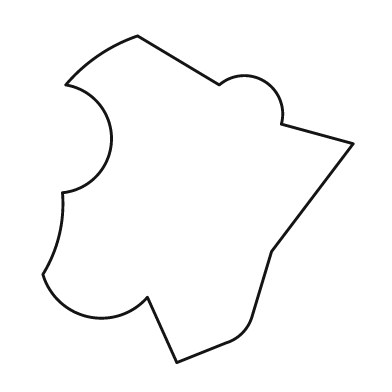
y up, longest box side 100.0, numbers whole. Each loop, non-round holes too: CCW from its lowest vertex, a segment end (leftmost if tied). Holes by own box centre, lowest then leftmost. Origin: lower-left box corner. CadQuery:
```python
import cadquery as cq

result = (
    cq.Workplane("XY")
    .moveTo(41.0, 0.0)
    .lineTo(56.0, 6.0)
    .threePointArc((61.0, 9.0), (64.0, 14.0))
    .lineTo(70.0, 34.0)
    .lineTo(95.0, 67.0)
    .lineTo(73.0, 73.0)
    .threePointArc((68.0, 86.0), (54.0, 85.0))
    .lineTo(29.0, 100.0)
    .threePointArc((17.0, 94.0), (7.0, 85.0))
    .threePointArc((21.0, 68.0), (6.0, 52.0))
    .threePointArc((5.0, 39.0), (0.0, 27.0))
    .threePointArc((14.0, 14.0), (32.0, 20.0))
    .close()
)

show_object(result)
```